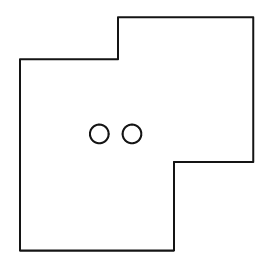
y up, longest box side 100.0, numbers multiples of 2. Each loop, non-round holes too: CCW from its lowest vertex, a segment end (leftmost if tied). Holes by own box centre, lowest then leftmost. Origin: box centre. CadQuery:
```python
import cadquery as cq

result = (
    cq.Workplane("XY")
    .moveTo(-50.0, -50.0)
    .lineTo(16.0, -50.0)
    .lineTo(16.0, -12.0)
    .lineTo(50.0, -12.0)
    .lineTo(50.0, 50.0)
    .lineTo(-8.0, 50.0)
    .lineTo(-8.0, 32.0)
    .lineTo(-50.0, 32.0)
    .close()
    .moveTo(-16.0, 0.0)
    .circle(4.0)
    .moveTo(-2.0, 0.0)
    .circle(4.0)
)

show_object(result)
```